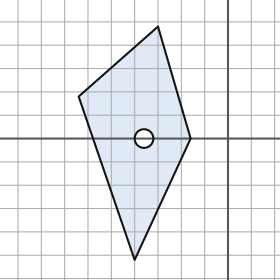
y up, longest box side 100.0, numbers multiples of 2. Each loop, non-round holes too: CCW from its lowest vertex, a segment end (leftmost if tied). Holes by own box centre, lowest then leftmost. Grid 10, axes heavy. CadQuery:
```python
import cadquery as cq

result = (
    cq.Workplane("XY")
    .moveTo(-40.0, -52.0)
    .lineTo(-16.0, 0.0)
    .lineTo(-30.0, 48.0)
    .lineTo(-64.0, 18.0)
    .close()
    .moveTo(-36.0, 0.0)
    .circle(4.0)
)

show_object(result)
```